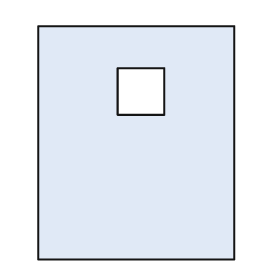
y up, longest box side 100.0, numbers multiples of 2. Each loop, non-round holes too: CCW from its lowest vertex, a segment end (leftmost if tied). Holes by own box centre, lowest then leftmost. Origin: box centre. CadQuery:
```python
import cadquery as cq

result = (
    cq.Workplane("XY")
    .moveTo(-42.0, -50.0)
    .lineTo(42.0, -50.0)
    .lineTo(42.0, 50.0)
    .lineTo(-42.0, 50.0)
    .close()
    .moveTo(-8.0, 12.0)
    .lineTo(12.0, 12.0)
    .lineTo(12.0, 32.0)
    .lineTo(-8.0, 32.0)
    .close()
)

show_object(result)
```